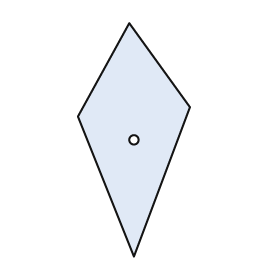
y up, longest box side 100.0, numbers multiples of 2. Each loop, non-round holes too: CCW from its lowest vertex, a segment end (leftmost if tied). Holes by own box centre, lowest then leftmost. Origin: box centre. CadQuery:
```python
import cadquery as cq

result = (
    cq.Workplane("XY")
    .moveTo(0.0, -50.0)
    .lineTo(24.0, 14.0)
    .lineTo(-2.0, 50.0)
    .lineTo(-24.0, 10.0)
    .close()
    .moveTo(0.0, 0.0)
    .circle(2.0)
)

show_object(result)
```